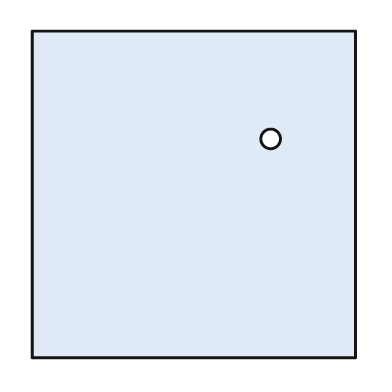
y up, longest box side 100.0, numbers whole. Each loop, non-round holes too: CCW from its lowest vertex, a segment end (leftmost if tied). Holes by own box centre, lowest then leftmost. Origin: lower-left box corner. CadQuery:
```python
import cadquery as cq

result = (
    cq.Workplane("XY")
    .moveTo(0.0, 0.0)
    .lineTo(99.0, 0.0)
    .lineTo(99.0, 100.0)
    .lineTo(0.0, 100.0)
    .close()
    .moveTo(73.0, 67.0)
    .circle(3.0)
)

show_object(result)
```